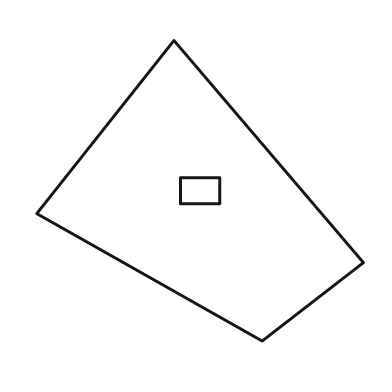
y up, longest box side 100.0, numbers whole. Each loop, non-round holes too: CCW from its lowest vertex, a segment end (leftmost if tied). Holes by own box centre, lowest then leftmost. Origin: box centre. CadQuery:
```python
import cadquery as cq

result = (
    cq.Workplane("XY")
    .moveTo(19.0, -46.0)
    .lineTo(50.0, -22.0)
    .lineTo(-8.0, 46.0)
    .lineTo(-50.0, -7.0)
    .close()
    .moveTo(-6.0, -4.0)
    .lineTo(6.0, -4.0)
    .lineTo(6.0, 4.0)
    .lineTo(-6.0, 4.0)
    .close()
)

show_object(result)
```